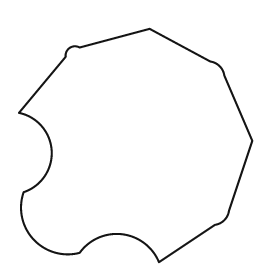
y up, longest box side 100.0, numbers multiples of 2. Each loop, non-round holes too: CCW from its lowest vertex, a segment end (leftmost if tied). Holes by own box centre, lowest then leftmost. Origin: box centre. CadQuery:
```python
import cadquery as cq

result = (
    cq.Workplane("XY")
    .moveTo(10.0, -50.0)
    .lineTo(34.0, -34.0)
    .threePointArc((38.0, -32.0), (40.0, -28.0))
    .lineTo(50.0, 2.0)
    .lineTo(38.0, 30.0)
    .threePointArc((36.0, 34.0), (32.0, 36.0))
    .lineTo(6.0, 50.0)
    .lineTo(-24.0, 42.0)
    .threePointArc((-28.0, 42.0), (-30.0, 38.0))
    .lineTo(-50.0, 14.0)
    .threePointArc((-36.0, -2.0), (-48.0, -20.0))
    .threePointArc((-44.0, -40.0), (-24.0, -46.0))
    .threePointArc((-6.0, -38.0), (10.0, -50.0))
    .close()
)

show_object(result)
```